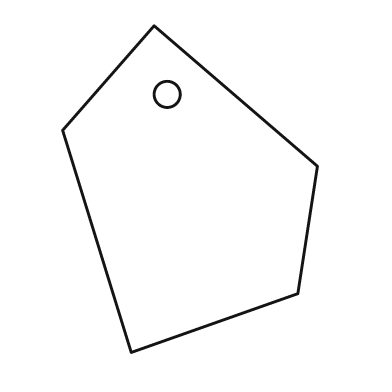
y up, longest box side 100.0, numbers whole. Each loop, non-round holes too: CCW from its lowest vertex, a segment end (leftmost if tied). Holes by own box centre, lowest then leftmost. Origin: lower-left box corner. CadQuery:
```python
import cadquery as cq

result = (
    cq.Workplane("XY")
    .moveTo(21.0, 0.0)
    .lineTo(72.0, 18.0)
    .lineTo(78.0, 57.0)
    .lineTo(28.0, 100.0)
    .lineTo(0.0, 68.0)
    .close()
    .moveTo(32.0, 79.0)
    .circle(4.0)
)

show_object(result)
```